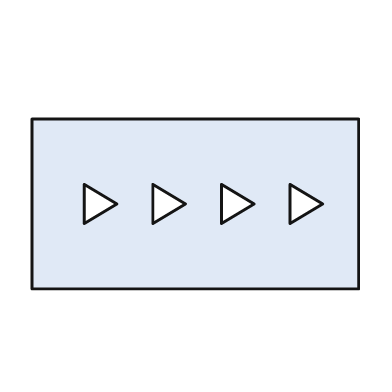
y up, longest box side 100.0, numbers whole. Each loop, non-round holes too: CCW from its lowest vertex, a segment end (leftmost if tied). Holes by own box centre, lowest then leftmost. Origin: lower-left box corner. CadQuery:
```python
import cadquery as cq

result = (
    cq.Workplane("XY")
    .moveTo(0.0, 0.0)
    .lineTo(100.0, 0.0)
    .lineTo(100.0, 52.0)
    .lineTo(0.0, 52.0)
    .close()
    .moveTo(16.0, 20.0)
    .lineTo(26.0, 26.0)
    .lineTo(16.0, 32.0)
    .close()
    .moveTo(37.0, 20.0)
    .lineTo(47.0, 26.0)
    .lineTo(37.0, 32.0)
    .close()
    .moveTo(58.0, 20.0)
    .lineTo(68.0, 26.0)
    .lineTo(58.0, 32.0)
    .close()
    .moveTo(79.0, 20.0)
    .lineTo(89.0, 26.0)
    .lineTo(79.0, 32.0)
    .close()
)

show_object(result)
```